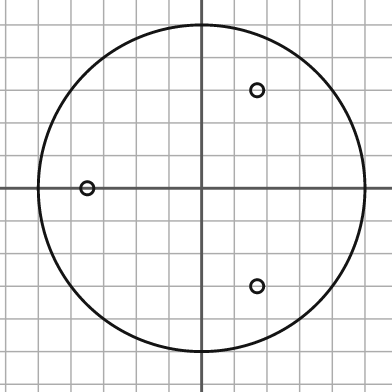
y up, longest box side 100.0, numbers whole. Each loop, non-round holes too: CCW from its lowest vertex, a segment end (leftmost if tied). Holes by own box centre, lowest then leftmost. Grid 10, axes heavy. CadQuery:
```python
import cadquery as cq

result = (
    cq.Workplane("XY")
    .moveTo(0.0, 0.0)
    .circle(50.0)
    .moveTo(17.0, -30.0)
    .circle(2.0)
    .moveTo(-35.0, 0.0)
    .circle(2.0)
    .moveTo(17.0, 30.0)
    .circle(2.0)
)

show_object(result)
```